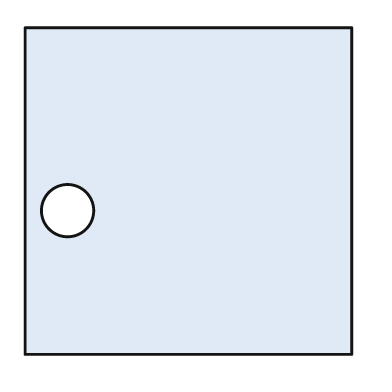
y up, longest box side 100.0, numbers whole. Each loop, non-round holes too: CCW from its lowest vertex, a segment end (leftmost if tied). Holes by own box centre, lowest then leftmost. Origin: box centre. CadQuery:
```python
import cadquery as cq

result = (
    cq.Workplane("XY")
    .moveTo(-50.0, -50.0)
    .lineTo(50.0, -50.0)
    .lineTo(50.0, 50.0)
    .lineTo(-50.0, 50.0)
    .close()
    .moveTo(-37.0, -6.0)
    .circle(8.0)
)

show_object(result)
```